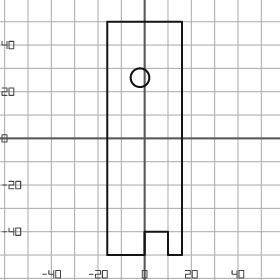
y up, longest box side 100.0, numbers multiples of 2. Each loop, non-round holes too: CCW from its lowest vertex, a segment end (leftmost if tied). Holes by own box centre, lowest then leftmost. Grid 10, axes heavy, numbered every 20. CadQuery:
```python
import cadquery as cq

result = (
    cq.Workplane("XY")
    .moveTo(-16.0, -50.0)
    .lineTo(0.0, -50.0)
    .lineTo(0.0, -40.0)
    .lineTo(10.0, -40.0)
    .lineTo(10.0, -50.0)
    .lineTo(16.0, -50.0)
    .lineTo(16.0, 50.0)
    .lineTo(-16.0, 50.0)
    .close()
    .moveTo(-2.0, 26.0)
    .circle(4.0)
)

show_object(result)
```